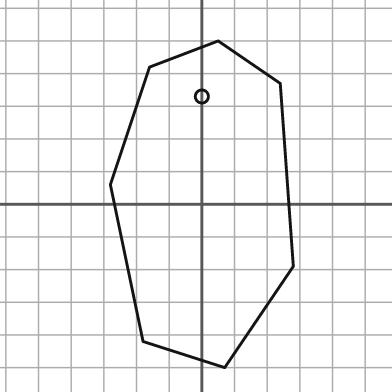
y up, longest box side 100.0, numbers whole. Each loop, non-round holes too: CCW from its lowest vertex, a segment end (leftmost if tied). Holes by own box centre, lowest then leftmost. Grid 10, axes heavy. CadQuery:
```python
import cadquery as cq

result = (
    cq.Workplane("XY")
    .moveTo(7.0, -50.0)
    .lineTo(28.0, -19.0)
    .lineTo(24.0, 37.0)
    .lineTo(5.0, 50.0)
    .lineTo(-16.0, 42.0)
    .lineTo(-28.0, 6.0)
    .lineTo(-18.0, -42.0)
    .close()
    .moveTo(0.0, 33.0)
    .circle(2.0)
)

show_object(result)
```